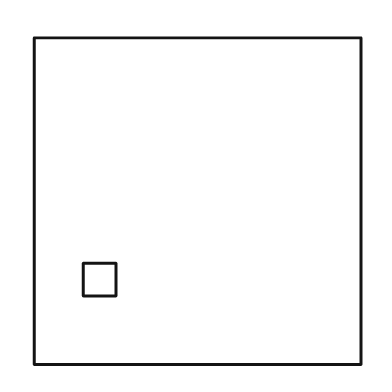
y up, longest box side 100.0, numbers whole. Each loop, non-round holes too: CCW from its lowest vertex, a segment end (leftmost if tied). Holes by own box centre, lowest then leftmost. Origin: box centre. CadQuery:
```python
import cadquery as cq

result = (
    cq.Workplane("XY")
    .moveTo(-50.0, -50.0)
    .lineTo(50.0, -50.0)
    .lineTo(50.0, 50.0)
    .lineTo(-50.0, 50.0)
    .close()
    .moveTo(-35.0, -29.0)
    .lineTo(-25.0, -29.0)
    .lineTo(-25.0, -19.0)
    .lineTo(-35.0, -19.0)
    .close()
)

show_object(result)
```